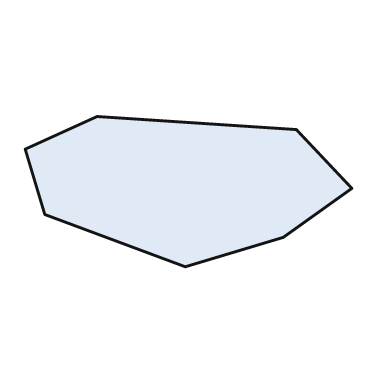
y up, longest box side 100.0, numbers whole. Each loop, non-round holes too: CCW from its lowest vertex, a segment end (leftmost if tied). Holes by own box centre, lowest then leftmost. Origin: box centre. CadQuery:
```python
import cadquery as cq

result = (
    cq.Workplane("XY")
    .moveTo(-1.0, -23.0)
    .lineTo(29.0, -14.0)
    .lineTo(50.0, 1.0)
    .lineTo(33.0, 19.0)
    .lineTo(-28.0, 23.0)
    .lineTo(-50.0, 13.0)
    .lineTo(-44.0, -7.0)
    .close()
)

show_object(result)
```